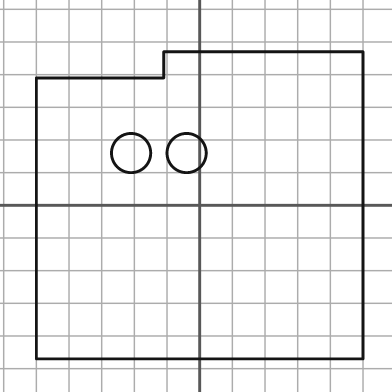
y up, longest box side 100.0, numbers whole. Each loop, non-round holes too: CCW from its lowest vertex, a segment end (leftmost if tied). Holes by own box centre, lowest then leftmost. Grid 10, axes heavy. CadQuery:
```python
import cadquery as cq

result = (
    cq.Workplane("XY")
    .moveTo(-50.0, -47.0)
    .lineTo(50.0, -47.0)
    .lineTo(50.0, 47.0)
    .lineTo(-11.0, 47.0)
    .lineTo(-11.0, 39.0)
    .lineTo(-50.0, 39.0)
    .close()
    .moveTo(-21.0, 16.0)
    .circle(6.0)
    .moveTo(-4.0, 16.0)
    .circle(6.0)
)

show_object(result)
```